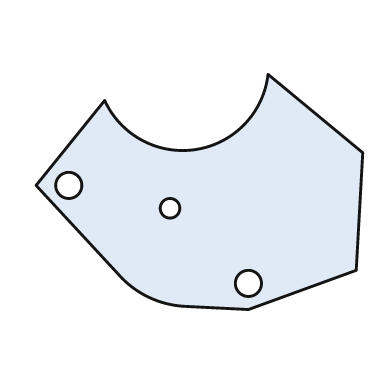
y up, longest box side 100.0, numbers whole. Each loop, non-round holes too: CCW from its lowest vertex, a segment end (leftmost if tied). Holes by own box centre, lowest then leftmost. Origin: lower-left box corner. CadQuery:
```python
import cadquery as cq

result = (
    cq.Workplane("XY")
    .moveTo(65.0, 0.0)
    .lineTo(98.0, 12.0)
    .lineTo(100.0, 48.0)
    .lineTo(71.0, 72.0)
    .threePointArc((49.0, 49.0), (21.0, 64.0))
    .lineTo(0.0, 38.0)
    .lineTo(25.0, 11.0)
    .threePointArc((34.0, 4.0), (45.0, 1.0))
    .close()
    .moveTo(65.0, 8.0)
    .circle(4.0)
    .moveTo(41.0, 31.0)
    .circle(3.0)
    .moveTo(10.0, 38.0)
    .circle(4.0)
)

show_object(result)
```